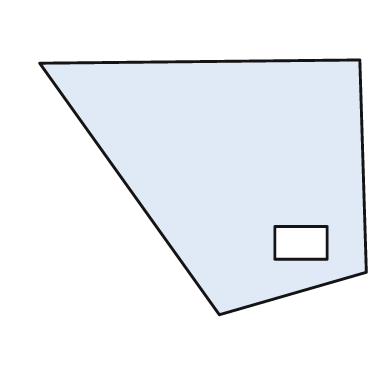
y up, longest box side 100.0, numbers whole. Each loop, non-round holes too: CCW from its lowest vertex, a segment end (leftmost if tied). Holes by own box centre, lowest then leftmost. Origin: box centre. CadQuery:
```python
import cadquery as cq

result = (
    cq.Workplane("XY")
    .moveTo(5.0, -39.0)
    .lineTo(50.0, -26.0)
    .lineTo(48.0, 39.0)
    .lineTo(-50.0, 38.0)
    .close()
    .moveTo(22.0, -22.0)
    .lineTo(38.0, -22.0)
    .lineTo(38.0, -12.0)
    .lineTo(22.0, -12.0)
    .close()
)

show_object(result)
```